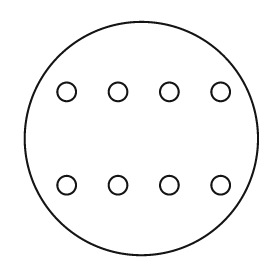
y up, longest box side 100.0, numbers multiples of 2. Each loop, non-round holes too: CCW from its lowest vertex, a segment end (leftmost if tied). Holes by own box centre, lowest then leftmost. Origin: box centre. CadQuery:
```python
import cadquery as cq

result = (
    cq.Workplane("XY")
    .moveTo(0.0, 0.0)
    .circle(50.0)
    .moveTo(-32.0, -20.0)
    .circle(4.0)
    .moveTo(-10.0, -20.0)
    .circle(4.0)
    .moveTo(12.0, -20.0)
    .circle(4.0)
    .moveTo(34.0, -20.0)
    .circle(4.0)
    .moveTo(-32.0, 20.0)
    .circle(4.0)
    .moveTo(-10.0, 20.0)
    .circle(4.0)
    .moveTo(12.0, 20.0)
    .circle(4.0)
    .moveTo(34.0, 20.0)
    .circle(4.0)
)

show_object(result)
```